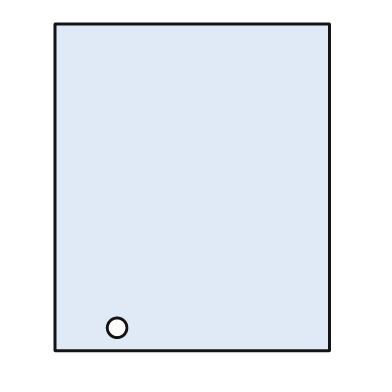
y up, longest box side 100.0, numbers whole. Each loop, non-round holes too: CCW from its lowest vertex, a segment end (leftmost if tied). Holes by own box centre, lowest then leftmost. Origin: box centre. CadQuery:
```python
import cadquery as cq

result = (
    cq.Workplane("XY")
    .moveTo(-42.0, -50.0)
    .lineTo(42.0, -50.0)
    .lineTo(42.0, 50.0)
    .lineTo(-42.0, 50.0)
    .close()
    .moveTo(-23.0, -43.0)
    .circle(3.0)
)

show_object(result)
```